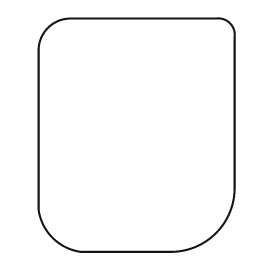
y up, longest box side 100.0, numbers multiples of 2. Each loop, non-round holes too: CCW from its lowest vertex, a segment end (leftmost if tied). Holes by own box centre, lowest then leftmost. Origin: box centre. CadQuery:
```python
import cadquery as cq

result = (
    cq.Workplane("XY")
    .moveTo(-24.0, -50.0)
    .lineTo(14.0, -50.0)
    .threePointArc((34.0, -42.0), (42.0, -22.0))
    .lineTo(42.0, 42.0)
    .threePointArc((40.0, 48.0), (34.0, 50.0))
    .lineTo(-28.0, 50.0)
    .threePointArc((-38.0, 46.0), (-42.0, 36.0))
    .lineTo(-42.0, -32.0)
    .threePointArc((-36.0, -44.0), (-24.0, -50.0))
    .close()
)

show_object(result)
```